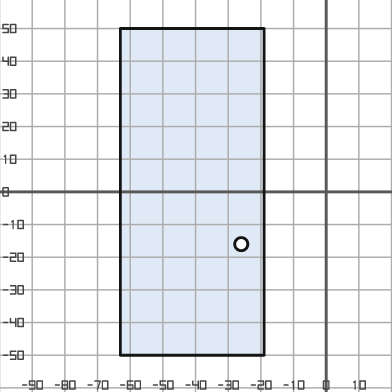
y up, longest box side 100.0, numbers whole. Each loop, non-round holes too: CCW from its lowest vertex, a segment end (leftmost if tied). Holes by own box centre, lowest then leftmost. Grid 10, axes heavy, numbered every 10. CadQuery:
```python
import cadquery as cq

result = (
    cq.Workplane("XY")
    .moveTo(-63.0, -50.0)
    .lineTo(-19.0, -50.0)
    .lineTo(-19.0, 50.0)
    .lineTo(-63.0, 50.0)
    .close()
    .moveTo(-26.0, -16.0)
    .circle(2.0)
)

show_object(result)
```